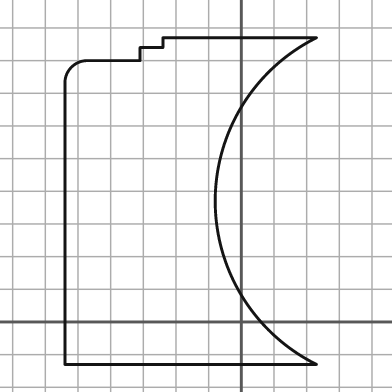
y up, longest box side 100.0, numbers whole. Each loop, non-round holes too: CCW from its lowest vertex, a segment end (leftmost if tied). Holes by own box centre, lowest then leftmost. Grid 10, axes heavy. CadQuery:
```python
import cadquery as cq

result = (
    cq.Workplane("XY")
    .moveTo(-54.0, -13.0)
    .lineTo(23.0, -13.0)
    .threePointArc((-8.0, 37.0), (23.0, 87.0))
    .lineTo(-24.0, 87.0)
    .lineTo(-24.0, 84.0)
    .lineTo(-31.0, 84.0)
    .lineTo(-31.0, 80.0)
    .lineTo(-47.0, 80.0)
    .threePointArc((-52.0, 78.0), (-54.0, 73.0))
    .close()
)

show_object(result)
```